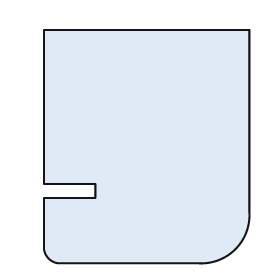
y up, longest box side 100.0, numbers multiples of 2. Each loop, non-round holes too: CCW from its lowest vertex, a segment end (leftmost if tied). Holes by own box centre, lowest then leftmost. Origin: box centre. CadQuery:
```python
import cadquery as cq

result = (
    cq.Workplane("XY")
    .moveTo(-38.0, -50.0)
    .lineTo(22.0, -50.0)
    .threePointArc((38.0, -44.0), (44.0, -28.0))
    .lineTo(44.0, 50.0)
    .lineTo(-44.0, 50.0)
    .lineTo(-44.0, -16.0)
    .lineTo(-22.0, -16.0)
    .lineTo(-22.0, -22.0)
    .lineTo(-44.0, -22.0)
    .lineTo(-44.0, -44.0)
    .threePointArc((-42.0, -48.0), (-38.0, -50.0))
    .close()
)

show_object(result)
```